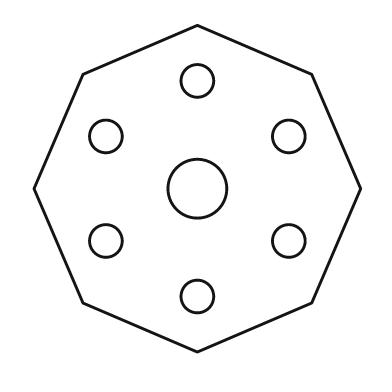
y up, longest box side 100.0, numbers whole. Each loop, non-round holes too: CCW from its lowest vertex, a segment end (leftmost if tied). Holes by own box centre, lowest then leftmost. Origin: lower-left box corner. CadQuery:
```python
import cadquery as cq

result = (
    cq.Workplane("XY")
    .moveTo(50.0, 0.0)
    .lineTo(85.0, 15.0)
    .lineTo(100.0, 50.0)
    .lineTo(85.0, 85.0)
    .lineTo(50.0, 100.0)
    .lineTo(15.0, 85.0)
    .lineTo(0.0, 50.0)
    .lineTo(15.0, 15.0)
    .close()
    .moveTo(50.0, 17.0)
    .circle(5.0)
    .moveTo(22.0, 34.0)
    .circle(5.0)
    .moveTo(78.0, 34.0)
    .circle(5.0)
    .moveTo(50.0, 50.0)
    .circle(9.0)
    .moveTo(22.0, 66.0)
    .circle(5.0)
    .moveTo(78.0, 66.0)
    .circle(5.0)
    .moveTo(50.0, 83.0)
    .circle(5.0)
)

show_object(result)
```